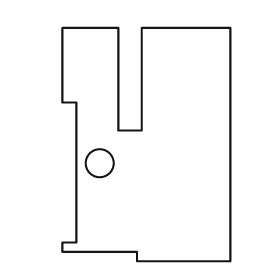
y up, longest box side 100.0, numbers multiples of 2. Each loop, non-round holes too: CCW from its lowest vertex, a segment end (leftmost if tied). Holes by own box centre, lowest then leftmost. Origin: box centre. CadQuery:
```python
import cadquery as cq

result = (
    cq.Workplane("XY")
    .moveTo(-4.0, -50.0)
    .lineTo(36.0, -50.0)
    .lineTo(36.0, 50.0)
    .lineTo(-2.0, 50.0)
    .lineTo(-2.0, 6.0)
    .lineTo(-12.0, 6.0)
    .lineTo(-12.0, 50.0)
    .lineTo(-36.0, 50.0)
    .lineTo(-36.0, 18.0)
    .lineTo(-30.0, 18.0)
    .lineTo(-30.0, -42.0)
    .lineTo(-36.0, -42.0)
    .lineTo(-36.0, -46.0)
    .lineTo(-4.0, -46.0)
    .close()
    .moveTo(-20.0, -8.0)
    .circle(6.0)
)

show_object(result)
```